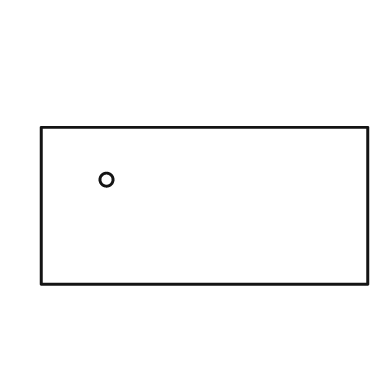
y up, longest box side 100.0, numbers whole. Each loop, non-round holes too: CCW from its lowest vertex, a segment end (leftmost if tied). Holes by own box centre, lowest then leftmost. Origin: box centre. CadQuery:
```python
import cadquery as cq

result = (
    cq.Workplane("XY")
    .moveTo(-50.0, -24.0)
    .lineTo(50.0, -24.0)
    .lineTo(50.0, 24.0)
    .lineTo(-50.0, 24.0)
    .close()
    .moveTo(-30.0, 8.0)
    .circle(2.0)
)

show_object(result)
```